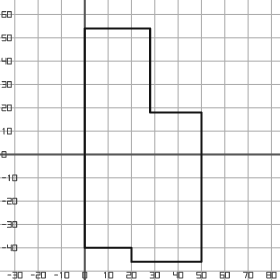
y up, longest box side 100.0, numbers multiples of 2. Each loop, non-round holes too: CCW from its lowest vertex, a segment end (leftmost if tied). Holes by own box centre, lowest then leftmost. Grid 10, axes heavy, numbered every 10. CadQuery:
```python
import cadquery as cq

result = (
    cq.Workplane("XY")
    .moveTo(20.0, -46.0)
    .lineTo(50.0, -46.0)
    .lineTo(50.0, 18.0)
    .lineTo(28.0, 18.0)
    .lineTo(28.0, 54.0)
    .lineTo(0.0, 54.0)
    .lineTo(0.0, -40.0)
    .lineTo(20.0, -40.0)
    .close()
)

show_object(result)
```